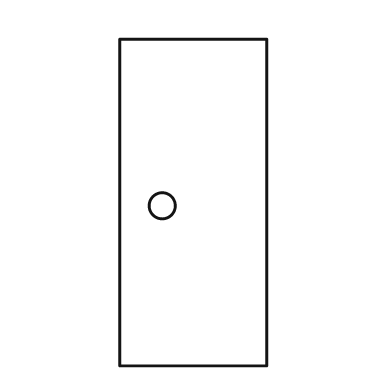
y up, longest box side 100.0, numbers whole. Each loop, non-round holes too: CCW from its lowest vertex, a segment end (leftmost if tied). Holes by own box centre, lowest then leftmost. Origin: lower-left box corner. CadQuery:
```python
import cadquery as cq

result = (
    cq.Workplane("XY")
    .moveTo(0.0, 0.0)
    .lineTo(45.0, 0.0)
    .lineTo(45.0, 100.0)
    .lineTo(0.0, 100.0)
    .close()
    .moveTo(13.0, 49.0)
    .circle(4.0)
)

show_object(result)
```